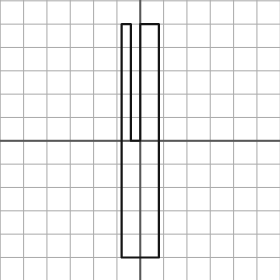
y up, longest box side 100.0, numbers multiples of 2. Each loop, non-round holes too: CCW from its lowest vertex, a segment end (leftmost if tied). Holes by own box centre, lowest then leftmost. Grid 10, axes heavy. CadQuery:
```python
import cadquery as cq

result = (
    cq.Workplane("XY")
    .moveTo(-8.0, -50.0)
    .lineTo(8.0, -50.0)
    .lineTo(8.0, 50.0)
    .lineTo(0.0, 50.0)
    .lineTo(0.0, 0.0)
    .lineTo(-4.0, 0.0)
    .lineTo(-4.0, 50.0)
    .lineTo(-8.0, 50.0)
    .close()
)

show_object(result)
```